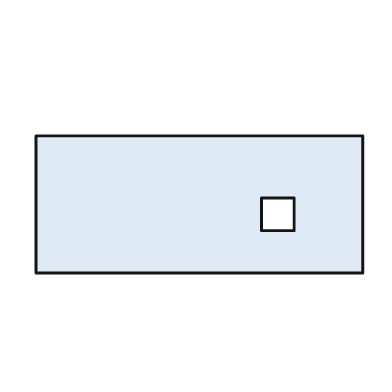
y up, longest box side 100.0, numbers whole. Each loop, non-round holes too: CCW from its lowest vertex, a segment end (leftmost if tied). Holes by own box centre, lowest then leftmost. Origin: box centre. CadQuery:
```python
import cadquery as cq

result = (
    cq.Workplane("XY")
    .moveTo(-50.0, -21.0)
    .lineTo(50.0, -21.0)
    .lineTo(50.0, 21.0)
    .lineTo(-50.0, 21.0)
    .close()
    .moveTo(19.0, -8.0)
    .lineTo(29.0, -8.0)
    .lineTo(29.0, 2.0)
    .lineTo(19.0, 2.0)
    .close()
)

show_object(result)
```